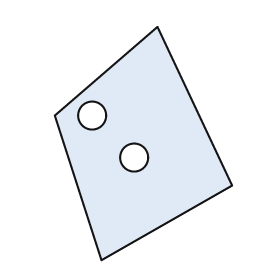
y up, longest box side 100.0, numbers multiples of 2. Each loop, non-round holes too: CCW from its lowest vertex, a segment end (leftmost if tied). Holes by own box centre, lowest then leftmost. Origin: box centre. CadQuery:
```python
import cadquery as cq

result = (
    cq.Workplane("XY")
    .moveTo(-18.0, -50.0)
    .lineTo(38.0, -18.0)
    .lineTo(6.0, 50.0)
    .lineTo(-38.0, 12.0)
    .close()
    .moveTo(-4.0, -6.0)
    .circle(6.0)
    .moveTo(-22.0, 12.0)
    .circle(6.0)
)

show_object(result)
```